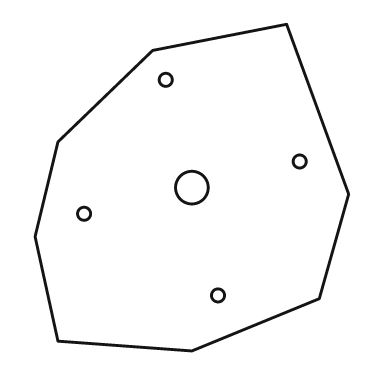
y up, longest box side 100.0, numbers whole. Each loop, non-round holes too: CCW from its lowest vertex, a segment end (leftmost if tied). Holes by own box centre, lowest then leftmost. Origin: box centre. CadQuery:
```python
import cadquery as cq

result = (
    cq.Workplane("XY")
    .moveTo(0.0, -50.0)
    .lineTo(39.0, -34.0)
    .lineTo(48.0, -2.0)
    .lineTo(29.0, 50.0)
    .lineTo(-12.0, 42.0)
    .lineTo(-41.0, 14.0)
    .lineTo(-48.0, -15.0)
    .lineTo(-41.0, -47.0)
    .close()
    .moveTo(8.0, -33.0)
    .circle(2.0)
    .moveTo(-33.0, -8.0)
    .circle(2.0)
    .moveTo(0.0, 0.0)
    .circle(5.0)
    .moveTo(33.0, 8.0)
    .circle(2.0)
    .moveTo(-8.0, 33.0)
    .circle(2.0)
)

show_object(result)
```